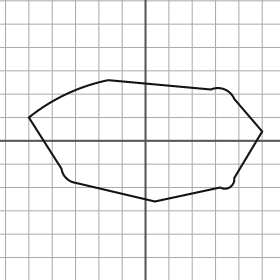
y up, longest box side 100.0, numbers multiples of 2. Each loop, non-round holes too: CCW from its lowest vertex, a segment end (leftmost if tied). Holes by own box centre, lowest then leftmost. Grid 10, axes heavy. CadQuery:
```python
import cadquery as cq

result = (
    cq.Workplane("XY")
    .moveTo(4.0, -26.0)
    .lineTo(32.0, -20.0)
    .threePointArc((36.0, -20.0), (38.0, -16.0))
    .lineTo(50.0, 4.0)
    .lineTo(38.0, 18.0)
    .threePointArc((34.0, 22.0), (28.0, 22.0))
    .lineTo(-16.0, 26.0)
    .threePointArc((-34.0, 20.0), (-50.0, 10.0))
    .lineTo(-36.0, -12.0)
    .threePointArc((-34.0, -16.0), (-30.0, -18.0))
    .close()
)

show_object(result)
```